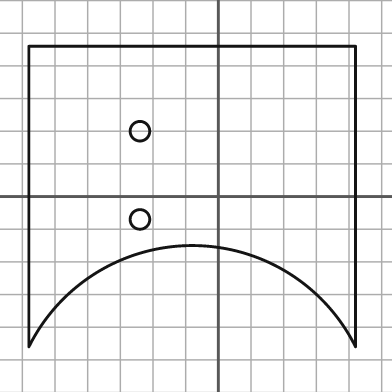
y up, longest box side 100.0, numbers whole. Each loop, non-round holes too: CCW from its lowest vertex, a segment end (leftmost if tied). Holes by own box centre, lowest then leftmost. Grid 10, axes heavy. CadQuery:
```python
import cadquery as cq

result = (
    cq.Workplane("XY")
    .moveTo(-58.0, -46.0)
    .threePointArc((-8.0, -15.0), (42.0, -46.0))
    .lineTo(42.0, 46.0)
    .lineTo(-58.0, 46.0)
    .close()
    .moveTo(-24.0, -7.0)
    .circle(3.0)
    .moveTo(-24.0, 20.0)
    .circle(3.0)
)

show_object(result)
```